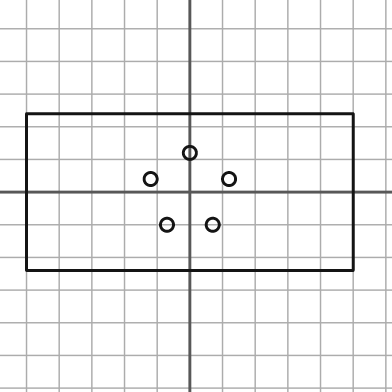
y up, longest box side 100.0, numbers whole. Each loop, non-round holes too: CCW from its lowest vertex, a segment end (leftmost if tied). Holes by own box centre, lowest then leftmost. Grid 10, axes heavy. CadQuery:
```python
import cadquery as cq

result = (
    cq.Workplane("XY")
    .moveTo(-50.0, -24.0)
    .lineTo(50.0, -24.0)
    .lineTo(50.0, 24.0)
    .lineTo(-50.0, 24.0)
    .close()
    .moveTo(-7.0, -10.0)
    .circle(2.0)
    .moveTo(7.0, -10.0)
    .circle(2.0)
    .moveTo(-12.0, 4.0)
    .circle(2.0)
    .moveTo(12.0, 4.0)
    .circle(2.0)
    .moveTo(0.0, 12.0)
    .circle(2.0)
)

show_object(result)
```